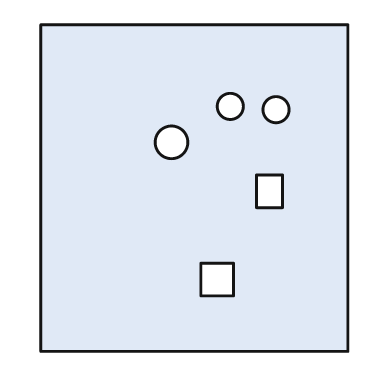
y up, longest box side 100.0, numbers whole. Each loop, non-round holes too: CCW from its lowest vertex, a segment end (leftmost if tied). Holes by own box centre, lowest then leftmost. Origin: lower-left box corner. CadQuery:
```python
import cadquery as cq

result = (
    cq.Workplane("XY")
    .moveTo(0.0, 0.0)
    .lineTo(94.0, 0.0)
    .lineTo(94.0, 100.0)
    .lineTo(0.0, 100.0)
    .close()
    .moveTo(49.0, 17.0)
    .lineTo(59.0, 17.0)
    .lineTo(59.0, 27.0)
    .lineTo(49.0, 27.0)
    .close()
    .moveTo(66.0, 44.0)
    .lineTo(74.0, 44.0)
    .lineTo(74.0, 54.0)
    .lineTo(66.0, 54.0)
    .close()
    .moveTo(40.0, 64.0)
    .circle(5.0)
    .moveTo(72.0, 74.0)
    .circle(4.0)
    .moveTo(58.0, 75.0)
    .circle(4.0)
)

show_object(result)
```